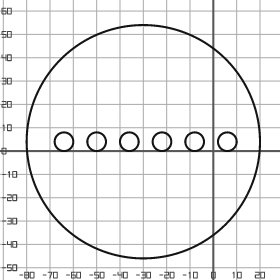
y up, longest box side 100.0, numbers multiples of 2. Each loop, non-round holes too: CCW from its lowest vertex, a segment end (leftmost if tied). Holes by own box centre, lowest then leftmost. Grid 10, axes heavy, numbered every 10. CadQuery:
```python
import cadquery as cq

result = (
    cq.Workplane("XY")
    .moveTo(-30.0, 4.0)
    .circle(50.0)
    .moveTo(-64.0, 4.0)
    .circle(4.0)
    .moveTo(-50.0, 4.0)
    .circle(4.0)
    .moveTo(-36.0, 4.0)
    .circle(4.0)
    .moveTo(-22.0, 4.0)
    .circle(4.0)
    .moveTo(-8.0, 4.0)
    .circle(4.0)
    .moveTo(6.0, 4.0)
    .circle(4.0)
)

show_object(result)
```